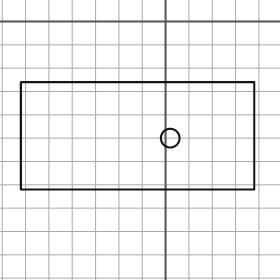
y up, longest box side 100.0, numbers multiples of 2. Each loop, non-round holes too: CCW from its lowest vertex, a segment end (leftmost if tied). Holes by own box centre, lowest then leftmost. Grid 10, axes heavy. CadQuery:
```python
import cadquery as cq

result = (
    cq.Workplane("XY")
    .moveTo(-62.0, -72.0)
    .lineTo(38.0, -72.0)
    .lineTo(38.0, -26.0)
    .lineTo(-62.0, -26.0)
    .close()
    .moveTo(2.0, -50.0)
    .circle(4.0)
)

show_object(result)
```